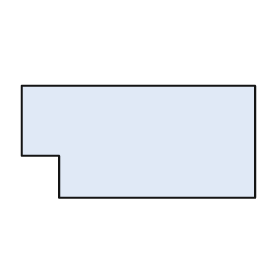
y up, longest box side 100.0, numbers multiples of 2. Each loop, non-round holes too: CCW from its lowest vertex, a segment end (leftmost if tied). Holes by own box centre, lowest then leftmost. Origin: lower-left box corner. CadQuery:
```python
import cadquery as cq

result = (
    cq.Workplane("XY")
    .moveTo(16.0, 0.0)
    .lineTo(100.0, 0.0)
    .lineTo(100.0, 48.0)
    .lineTo(0.0, 48.0)
    .lineTo(0.0, 18.0)
    .lineTo(16.0, 18.0)
    .close()
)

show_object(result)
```